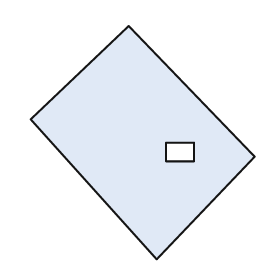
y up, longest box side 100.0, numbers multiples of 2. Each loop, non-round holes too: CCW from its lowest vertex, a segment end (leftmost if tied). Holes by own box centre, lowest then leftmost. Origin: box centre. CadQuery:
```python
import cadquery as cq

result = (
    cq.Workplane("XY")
    .moveTo(6.0, -50.0)
    .lineTo(48.0, -6.0)
    .lineTo(-6.0, 50.0)
    .lineTo(-48.0, 10.0)
    .close()
    .moveTo(10.0, -8.0)
    .lineTo(22.0, -8.0)
    .lineTo(22.0, 0.0)
    .lineTo(10.0, 0.0)
    .close()
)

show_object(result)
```